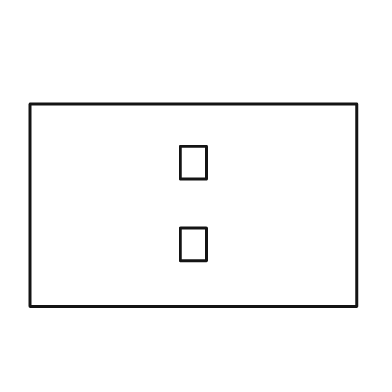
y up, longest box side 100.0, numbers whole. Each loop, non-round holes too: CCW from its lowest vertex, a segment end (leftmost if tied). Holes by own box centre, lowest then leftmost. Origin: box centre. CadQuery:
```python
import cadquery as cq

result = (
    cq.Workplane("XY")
    .moveTo(-50.0, -31.0)
    .lineTo(50.0, -31.0)
    .lineTo(50.0, 31.0)
    .lineTo(-50.0, 31.0)
    .close()
    .moveTo(-4.0, -17.0)
    .lineTo(4.0, -17.0)
    .lineTo(4.0, -7.0)
    .lineTo(-4.0, -7.0)
    .close()
    .moveTo(-4.0, 8.0)
    .lineTo(4.0, 8.0)
    .lineTo(4.0, 18.0)
    .lineTo(-4.0, 18.0)
    .close()
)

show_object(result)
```